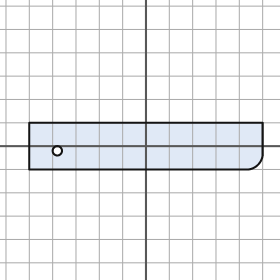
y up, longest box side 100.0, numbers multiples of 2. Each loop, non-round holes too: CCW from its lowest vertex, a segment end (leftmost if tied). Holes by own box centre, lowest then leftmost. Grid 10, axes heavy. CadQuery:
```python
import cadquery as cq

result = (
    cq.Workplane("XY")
    .moveTo(-50.0, -10.0)
    .lineTo(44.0, -10.0)
    .threePointArc((48.0, -8.0), (50.0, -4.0))
    .lineTo(50.0, 10.0)
    .lineTo(-50.0, 10.0)
    .close()
    .moveTo(-38.0, -2.0)
    .circle(2.0)
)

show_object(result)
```